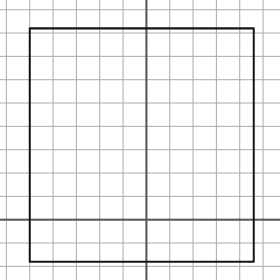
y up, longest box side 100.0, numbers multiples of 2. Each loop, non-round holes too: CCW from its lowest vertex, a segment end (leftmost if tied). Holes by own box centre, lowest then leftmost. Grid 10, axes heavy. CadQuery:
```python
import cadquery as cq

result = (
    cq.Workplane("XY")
    .moveTo(-50.0, -18.0)
    .lineTo(46.0, -18.0)
    .lineTo(46.0, 82.0)
    .lineTo(-50.0, 82.0)
    .close()
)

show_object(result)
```